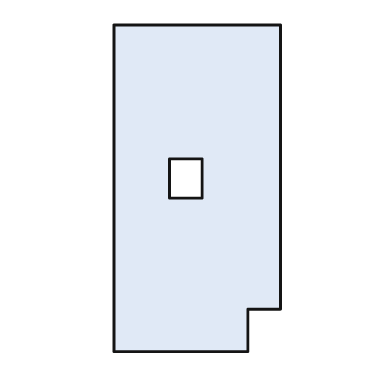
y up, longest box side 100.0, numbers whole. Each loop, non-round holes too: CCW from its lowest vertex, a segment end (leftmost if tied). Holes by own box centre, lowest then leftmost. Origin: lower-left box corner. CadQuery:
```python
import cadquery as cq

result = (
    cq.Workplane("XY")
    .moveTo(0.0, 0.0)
    .lineTo(41.0, 0.0)
    .lineTo(41.0, 13.0)
    .lineTo(51.0, 13.0)
    .lineTo(51.0, 100.0)
    .lineTo(0.0, 100.0)
    .close()
    .moveTo(17.0, 47.0)
    .lineTo(27.0, 47.0)
    .lineTo(27.0, 59.0)
    .lineTo(17.0, 59.0)
    .close()
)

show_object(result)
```